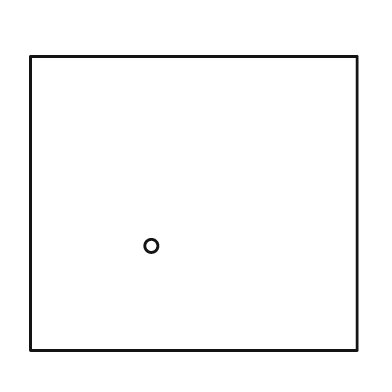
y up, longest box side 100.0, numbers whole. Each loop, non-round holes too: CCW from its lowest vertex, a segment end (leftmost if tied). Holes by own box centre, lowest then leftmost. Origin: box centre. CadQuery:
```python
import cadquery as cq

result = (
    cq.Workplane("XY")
    .moveTo(-50.0, -45.0)
    .lineTo(50.0, -45.0)
    .lineTo(50.0, 45.0)
    .lineTo(-50.0, 45.0)
    .close()
    .moveTo(-13.0, -13.0)
    .circle(2.0)
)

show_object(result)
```